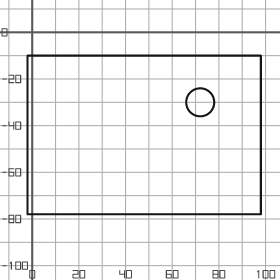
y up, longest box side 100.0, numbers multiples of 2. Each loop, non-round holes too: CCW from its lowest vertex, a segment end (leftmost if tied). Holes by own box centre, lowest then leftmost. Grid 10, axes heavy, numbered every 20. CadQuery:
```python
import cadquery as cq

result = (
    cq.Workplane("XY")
    .moveTo(-2.0, -78.0)
    .lineTo(98.0, -78.0)
    .lineTo(98.0, -10.0)
    .lineTo(-2.0, -10.0)
    .close()
    .moveTo(72.0, -30.0)
    .circle(6.0)
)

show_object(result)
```